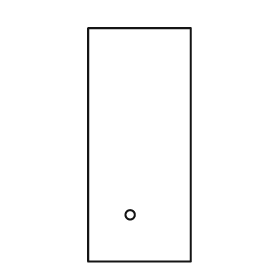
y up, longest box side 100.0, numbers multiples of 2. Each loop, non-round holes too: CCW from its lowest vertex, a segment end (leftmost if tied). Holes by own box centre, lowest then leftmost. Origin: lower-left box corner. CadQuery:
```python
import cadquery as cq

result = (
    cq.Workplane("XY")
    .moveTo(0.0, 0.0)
    .lineTo(44.0, 0.0)
    .lineTo(44.0, 100.0)
    .lineTo(0.0, 100.0)
    .close()
    .moveTo(18.0, 20.0)
    .circle(2.0)
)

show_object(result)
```